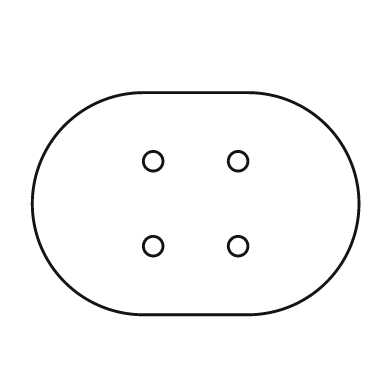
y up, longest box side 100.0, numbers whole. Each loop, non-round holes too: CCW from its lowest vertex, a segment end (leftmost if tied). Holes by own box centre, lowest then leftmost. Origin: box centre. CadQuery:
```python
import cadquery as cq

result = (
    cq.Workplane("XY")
    .moveTo(-16.0, -34.0)
    .lineTo(16.0, -34.0)
    .threePointArc((50.0, 0.0), (16.0, 34.0))
    .lineTo(-16.0, 34.0)
    .threePointArc((-50.0, 0.0), (-16.0, -34.0))
    .close()
    .moveTo(-13.0, -13.0)
    .circle(3.0)
    .moveTo(13.0, -13.0)
    .circle(3.0)
    .moveTo(-13.0, 13.0)
    .circle(3.0)
    .moveTo(13.0, 13.0)
    .circle(3.0)
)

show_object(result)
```